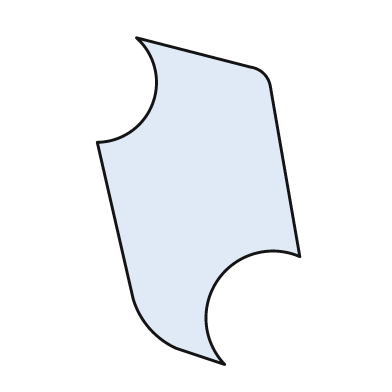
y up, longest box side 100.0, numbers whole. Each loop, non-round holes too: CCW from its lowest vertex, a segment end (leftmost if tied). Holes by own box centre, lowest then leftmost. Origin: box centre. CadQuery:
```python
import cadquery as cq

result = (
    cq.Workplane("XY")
    .moveTo(8.0, -50.0)
    .threePointArc((6.0, -24.0), (31.0, -17.0))
    .lineTo(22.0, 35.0)
    .threePointArc((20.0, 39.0), (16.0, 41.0))
    .lineTo(-19.0, 50.0)
    .threePointArc((-14.0, 30.0), (-31.0, 18.0))
    .lineTo(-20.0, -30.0)
    .threePointArc((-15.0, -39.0), (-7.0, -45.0))
    .close()
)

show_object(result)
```